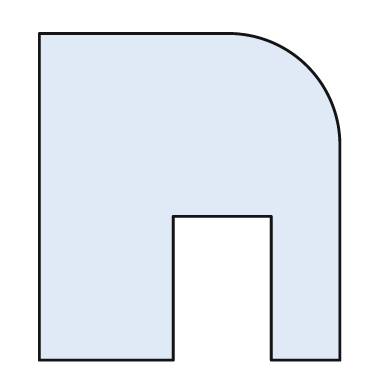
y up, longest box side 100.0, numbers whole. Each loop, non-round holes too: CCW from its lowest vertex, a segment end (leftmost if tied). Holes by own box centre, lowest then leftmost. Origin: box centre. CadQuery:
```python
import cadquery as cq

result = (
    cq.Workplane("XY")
    .moveTo(-46.0, -50.0)
    .lineTo(-5.0, -50.0)
    .lineTo(-5.0, -6.0)
    .lineTo(25.0, -6.0)
    .lineTo(25.0, -50.0)
    .lineTo(46.0, -50.0)
    .lineTo(46.0, 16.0)
    .threePointArc((36.0, 40.0), (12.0, 50.0))
    .lineTo(-46.0, 50.0)
    .close()
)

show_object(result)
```